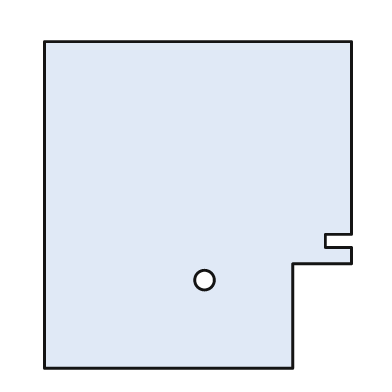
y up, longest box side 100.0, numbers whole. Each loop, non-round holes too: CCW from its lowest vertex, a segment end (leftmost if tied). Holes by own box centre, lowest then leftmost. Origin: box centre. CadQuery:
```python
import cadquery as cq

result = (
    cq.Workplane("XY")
    .moveTo(-47.0, -50.0)
    .lineTo(29.0, -50.0)
    .lineTo(29.0, -18.0)
    .lineTo(47.0, -18.0)
    .lineTo(47.0, -13.0)
    .lineTo(39.0, -13.0)
    .lineTo(39.0, -9.0)
    .lineTo(47.0, -9.0)
    .lineTo(47.0, 50.0)
    .lineTo(-47.0, 50.0)
    .close()
    .moveTo(2.0, -23.0)
    .circle(3.0)
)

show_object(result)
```